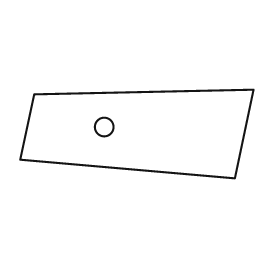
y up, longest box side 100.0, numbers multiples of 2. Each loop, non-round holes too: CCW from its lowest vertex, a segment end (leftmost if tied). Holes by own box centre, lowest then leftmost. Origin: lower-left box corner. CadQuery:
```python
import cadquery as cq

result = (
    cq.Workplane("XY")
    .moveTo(92.0, 0.0)
    .lineTo(100.0, 38.0)
    .lineTo(6.0, 36.0)
    .lineTo(0.0, 8.0)
    .close()
    .moveTo(36.0, 22.0)
    .circle(4.0)
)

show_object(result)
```